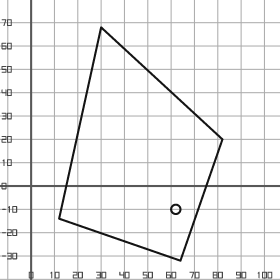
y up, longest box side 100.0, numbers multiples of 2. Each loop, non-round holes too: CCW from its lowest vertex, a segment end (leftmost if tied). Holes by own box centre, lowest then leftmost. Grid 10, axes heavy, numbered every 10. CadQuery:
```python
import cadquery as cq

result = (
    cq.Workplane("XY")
    .moveTo(64.0, -32.0)
    .lineTo(82.0, 20.0)
    .lineTo(30.0, 68.0)
    .lineTo(12.0, -14.0)
    .close()
    .moveTo(62.0, -10.0)
    .circle(2.0)
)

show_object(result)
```